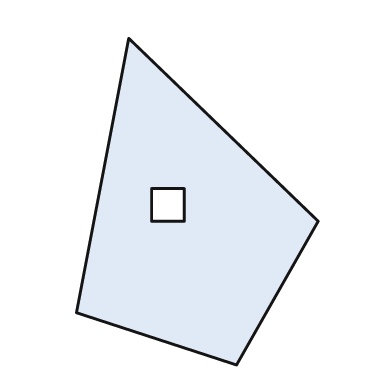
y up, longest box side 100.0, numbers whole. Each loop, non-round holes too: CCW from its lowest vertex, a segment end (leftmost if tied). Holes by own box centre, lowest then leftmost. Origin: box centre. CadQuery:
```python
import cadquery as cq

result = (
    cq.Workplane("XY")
    .moveTo(12.0, -50.0)
    .lineTo(37.0, -6.0)
    .lineTo(-21.0, 50.0)
    .lineTo(-37.0, -34.0)
    .close()
    .moveTo(-14.0, -6.0)
    .lineTo(-4.0, -6.0)
    .lineTo(-4.0, 4.0)
    .lineTo(-14.0, 4.0)
    .close()
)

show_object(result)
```